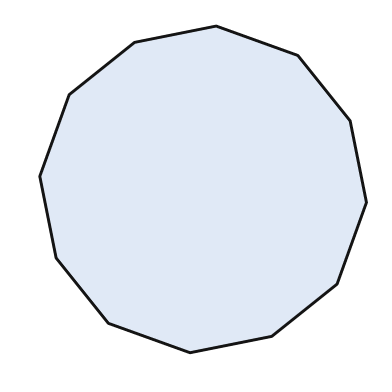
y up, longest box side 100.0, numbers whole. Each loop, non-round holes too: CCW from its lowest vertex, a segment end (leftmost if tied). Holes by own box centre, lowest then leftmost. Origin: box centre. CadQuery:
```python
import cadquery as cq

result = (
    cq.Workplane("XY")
    .moveTo(-4.0, -50.0)
    .lineTo(21.0, -45.0)
    .lineTo(41.0, -29.0)
    .lineTo(50.0, -4.0)
    .lineTo(45.0, 21.0)
    .lineTo(29.0, 41.0)
    .lineTo(4.0, 50.0)
    .lineTo(-21.0, 45.0)
    .lineTo(-41.0, 29.0)
    .lineTo(-50.0, 4.0)
    .lineTo(-45.0, -21.0)
    .lineTo(-29.0, -41.0)
    .close()
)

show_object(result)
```